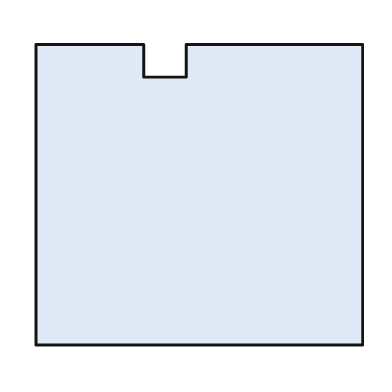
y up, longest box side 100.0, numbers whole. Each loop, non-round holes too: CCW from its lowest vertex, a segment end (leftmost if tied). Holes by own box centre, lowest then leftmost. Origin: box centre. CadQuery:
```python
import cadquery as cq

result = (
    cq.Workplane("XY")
    .moveTo(-50.0, -46.0)
    .lineTo(50.0, -46.0)
    .lineTo(50.0, 46.0)
    .lineTo(-4.0, 46.0)
    .lineTo(-4.0, 36.0)
    .lineTo(-17.0, 36.0)
    .lineTo(-17.0, 46.0)
    .lineTo(-50.0, 46.0)
    .close()
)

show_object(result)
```